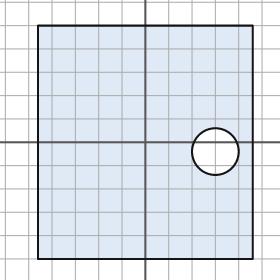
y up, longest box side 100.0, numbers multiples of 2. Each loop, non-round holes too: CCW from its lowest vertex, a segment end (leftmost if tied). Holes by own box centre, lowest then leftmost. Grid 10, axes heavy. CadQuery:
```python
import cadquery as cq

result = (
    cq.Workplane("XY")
    .moveTo(-46.0, -50.0)
    .lineTo(46.0, -50.0)
    .lineTo(46.0, 50.0)
    .lineTo(-46.0, 50.0)
    .close()
    .moveTo(30.0, -4.0)
    .circle(10.0)
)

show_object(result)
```